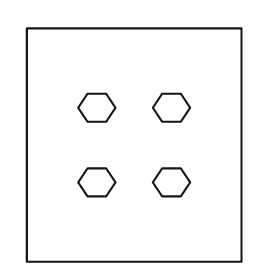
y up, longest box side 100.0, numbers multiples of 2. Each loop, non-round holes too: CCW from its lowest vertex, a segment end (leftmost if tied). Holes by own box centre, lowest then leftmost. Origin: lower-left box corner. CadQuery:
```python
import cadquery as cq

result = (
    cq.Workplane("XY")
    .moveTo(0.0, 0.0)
    .lineTo(92.0, 0.0)
    .lineTo(92.0, 100.0)
    .lineTo(0.0, 100.0)
    .close()
    .moveTo(26.0, 28.0)
    .lineTo(34.0, 28.0)
    .lineTo(38.0, 34.0)
    .lineTo(34.0, 40.0)
    .lineTo(26.0, 40.0)
    .lineTo(22.0, 34.0)
    .close()
    .moveTo(58.0, 28.0)
    .lineTo(66.0, 28.0)
    .lineTo(70.0, 34.0)
    .lineTo(66.0, 40.0)
    .lineTo(58.0, 40.0)
    .lineTo(54.0, 34.0)
    .close()
    .moveTo(26.0, 60.0)
    .lineTo(34.0, 60.0)
    .lineTo(38.0, 66.0)
    .lineTo(34.0, 72.0)
    .lineTo(26.0, 72.0)
    .lineTo(22.0, 66.0)
    .close()
    .moveTo(58.0, 60.0)
    .lineTo(66.0, 60.0)
    .lineTo(70.0, 66.0)
    .lineTo(66.0, 72.0)
    .lineTo(58.0, 72.0)
    .lineTo(54.0, 66.0)
    .close()
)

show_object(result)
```